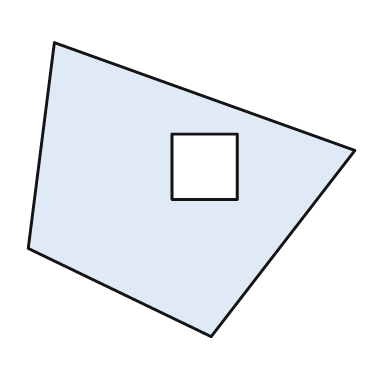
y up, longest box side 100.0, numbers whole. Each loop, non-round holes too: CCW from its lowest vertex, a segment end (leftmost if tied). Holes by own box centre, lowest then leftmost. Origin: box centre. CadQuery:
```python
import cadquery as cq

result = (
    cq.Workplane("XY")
    .moveTo(6.0, -45.0)
    .lineTo(50.0, 12.0)
    .lineTo(-42.0, 45.0)
    .lineTo(-50.0, -18.0)
    .close()
    .moveTo(-6.0, -3.0)
    .lineTo(14.0, -3.0)
    .lineTo(14.0, 17.0)
    .lineTo(-6.0, 17.0)
    .close()
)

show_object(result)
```